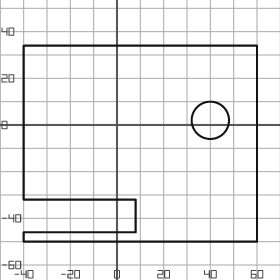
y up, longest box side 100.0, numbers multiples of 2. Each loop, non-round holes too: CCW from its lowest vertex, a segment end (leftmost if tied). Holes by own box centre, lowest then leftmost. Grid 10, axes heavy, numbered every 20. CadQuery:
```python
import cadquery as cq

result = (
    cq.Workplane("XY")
    .moveTo(-40.0, -50.0)
    .lineTo(60.0, -50.0)
    .lineTo(60.0, 34.0)
    .lineTo(-40.0, 34.0)
    .lineTo(-40.0, -32.0)
    .lineTo(8.0, -32.0)
    .lineTo(8.0, -46.0)
    .lineTo(-40.0, -46.0)
    .close()
    .moveTo(40.0, 2.0)
    .circle(8.0)
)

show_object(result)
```